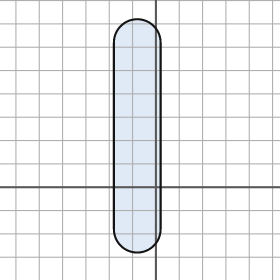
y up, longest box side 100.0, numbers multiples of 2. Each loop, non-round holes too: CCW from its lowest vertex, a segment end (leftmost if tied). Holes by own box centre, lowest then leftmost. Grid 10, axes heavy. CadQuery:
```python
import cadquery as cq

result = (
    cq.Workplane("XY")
    .moveTo(-18.0, -18.0)
    .threePointArc((-8.0, -28.0), (2.0, -18.0))
    .lineTo(2.0, 62.0)
    .threePointArc((-8.0, 72.0), (-18.0, 62.0))
    .close()
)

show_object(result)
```